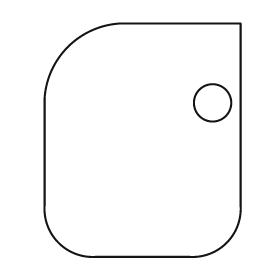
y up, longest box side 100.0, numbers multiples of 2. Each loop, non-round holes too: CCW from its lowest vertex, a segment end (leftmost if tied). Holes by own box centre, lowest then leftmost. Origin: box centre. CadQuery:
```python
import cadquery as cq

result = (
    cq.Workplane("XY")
    .moveTo(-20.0, -50.0)
    .lineTo(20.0, -50.0)
    .threePointArc((36.0, -44.0), (42.0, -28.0))
    .lineTo(42.0, 50.0)
    .lineTo(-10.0, 50.0)
    .threePointArc((-32.0, 40.0), (-42.0, 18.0))
    .lineTo(-42.0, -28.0)
    .threePointArc((-36.0, -44.0), (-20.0, -50.0))
    .close()
    .moveTo(30.0, 16.0)
    .circle(8.0)
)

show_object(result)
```